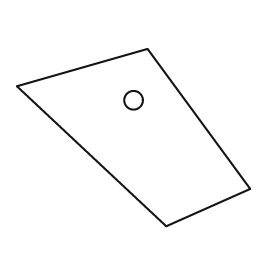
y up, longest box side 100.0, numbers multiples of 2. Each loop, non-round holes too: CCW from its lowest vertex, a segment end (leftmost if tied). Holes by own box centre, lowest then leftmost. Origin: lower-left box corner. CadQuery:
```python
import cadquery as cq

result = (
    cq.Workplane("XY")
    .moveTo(64.0, 0.0)
    .lineTo(100.0, 16.0)
    .lineTo(56.0, 76.0)
    .lineTo(0.0, 60.0)
    .close()
    .moveTo(50.0, 54.0)
    .circle(4.0)
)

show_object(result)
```